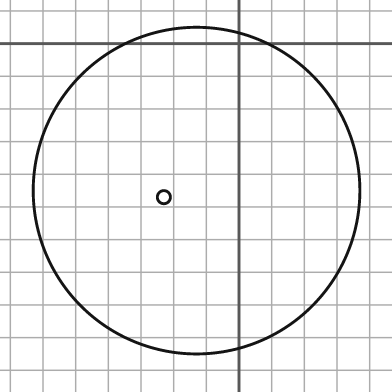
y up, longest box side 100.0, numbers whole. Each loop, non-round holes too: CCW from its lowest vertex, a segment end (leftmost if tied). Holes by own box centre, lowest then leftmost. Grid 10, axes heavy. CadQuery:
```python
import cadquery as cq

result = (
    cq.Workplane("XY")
    .moveTo(-13.0, -45.0)
    .circle(50.0)
    .moveTo(-23.0, -47.0)
    .circle(2.0)
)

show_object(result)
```